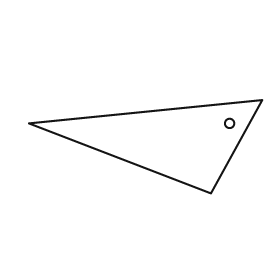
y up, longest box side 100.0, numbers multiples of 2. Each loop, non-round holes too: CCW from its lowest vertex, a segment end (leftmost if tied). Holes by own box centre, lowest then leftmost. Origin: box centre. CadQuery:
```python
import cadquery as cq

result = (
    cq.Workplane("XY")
    .moveTo(28.0, -20.0)
    .lineTo(50.0, 20.0)
    .lineTo(-50.0, 10.0)
    .close()
    .moveTo(36.0, 10.0)
    .circle(2.0)
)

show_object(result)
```